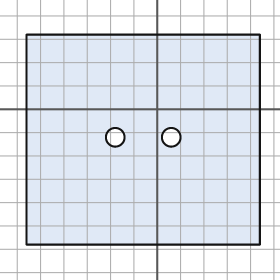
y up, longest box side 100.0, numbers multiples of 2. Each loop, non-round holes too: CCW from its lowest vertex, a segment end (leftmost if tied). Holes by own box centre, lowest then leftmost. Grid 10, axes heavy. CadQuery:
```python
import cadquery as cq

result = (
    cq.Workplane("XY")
    .moveTo(-56.0, -58.0)
    .lineTo(44.0, -58.0)
    .lineTo(44.0, 32.0)
    .lineTo(-56.0, 32.0)
    .close()
    .moveTo(-18.0, -12.0)
    .circle(4.0)
    .moveTo(6.0, -12.0)
    .circle(4.0)
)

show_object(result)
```